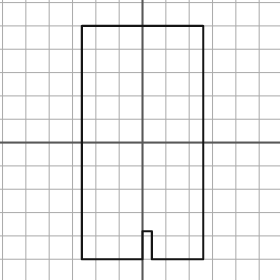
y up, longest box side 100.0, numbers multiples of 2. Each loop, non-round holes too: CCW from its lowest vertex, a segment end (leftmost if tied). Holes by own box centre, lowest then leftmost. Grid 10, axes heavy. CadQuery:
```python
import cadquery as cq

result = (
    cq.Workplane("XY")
    .moveTo(-26.0, -50.0)
    .lineTo(0.0, -50.0)
    .lineTo(0.0, -38.0)
    .lineTo(4.0, -38.0)
    .lineTo(4.0, -50.0)
    .lineTo(26.0, -50.0)
    .lineTo(26.0, 50.0)
    .lineTo(-26.0, 50.0)
    .close()
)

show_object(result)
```